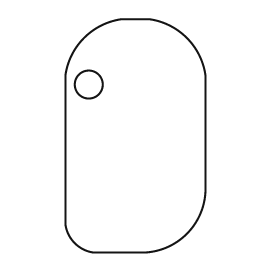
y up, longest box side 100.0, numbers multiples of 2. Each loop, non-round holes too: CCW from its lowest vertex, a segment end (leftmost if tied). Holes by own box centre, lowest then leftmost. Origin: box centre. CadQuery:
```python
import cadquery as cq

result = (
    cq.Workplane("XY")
    .moveTo(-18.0, -50.0)
    .lineTo(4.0, -50.0)
    .threePointArc((22.0, -42.0), (30.0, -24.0))
    .lineTo(30.0, 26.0)
    .threePointArc((22.0, 42.0), (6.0, 50.0))
    .lineTo(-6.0, 50.0)
    .threePointArc((-22.0, 42.0), (-30.0, 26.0))
    .lineTo(-30.0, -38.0)
    .threePointArc((-26.0, -46.0), (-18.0, -50.0))
    .close()
    .moveTo(-20.0, 22.0)
    .circle(6.0)
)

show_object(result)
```